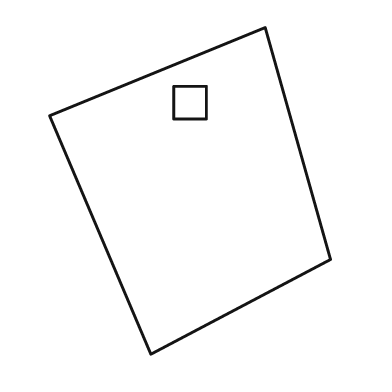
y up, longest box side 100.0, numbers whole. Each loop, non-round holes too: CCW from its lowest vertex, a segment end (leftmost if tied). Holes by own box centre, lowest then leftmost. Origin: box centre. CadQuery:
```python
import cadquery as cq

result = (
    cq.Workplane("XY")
    .moveTo(-12.0, -50.0)
    .lineTo(43.0, -21.0)
    .lineTo(23.0, 50.0)
    .lineTo(-43.0, 23.0)
    .close()
    .moveTo(-5.0, 22.0)
    .lineTo(5.0, 22.0)
    .lineTo(5.0, 32.0)
    .lineTo(-5.0, 32.0)
    .close()
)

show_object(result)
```